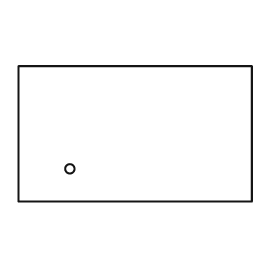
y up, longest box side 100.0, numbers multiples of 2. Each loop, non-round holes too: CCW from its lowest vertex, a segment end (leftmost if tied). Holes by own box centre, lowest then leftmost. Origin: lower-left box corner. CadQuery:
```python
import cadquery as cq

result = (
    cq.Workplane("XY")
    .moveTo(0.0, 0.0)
    .lineTo(100.0, 0.0)
    .lineTo(100.0, 58.0)
    .lineTo(0.0, 58.0)
    .close()
    .moveTo(22.0, 14.0)
    .circle(2.0)
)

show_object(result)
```